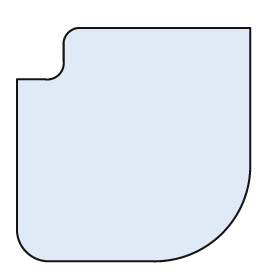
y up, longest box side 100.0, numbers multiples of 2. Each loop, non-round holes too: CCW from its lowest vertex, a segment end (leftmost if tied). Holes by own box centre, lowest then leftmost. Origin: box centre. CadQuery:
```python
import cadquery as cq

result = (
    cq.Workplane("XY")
    .moveTo(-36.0, -50.0)
    .lineTo(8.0, -50.0)
    .threePointArc((38.0, -38.0), (50.0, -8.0))
    .lineTo(50.0, 50.0)
    .lineTo(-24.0, 50.0)
    .threePointArc((-28.0, 48.0), (-30.0, 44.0))
    .lineTo(-30.0, 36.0)
    .threePointArc((-32.0, 30.0), (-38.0, 28.0))
    .lineTo(-50.0, 28.0)
    .lineTo(-50.0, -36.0)
    .threePointArc((-46.0, -46.0), (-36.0, -50.0))
    .close()
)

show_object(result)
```